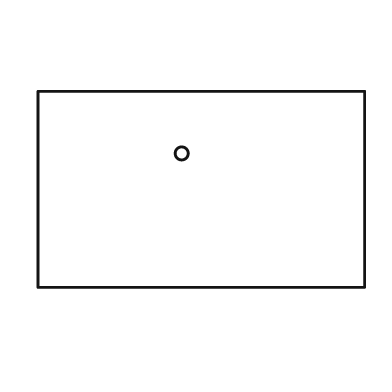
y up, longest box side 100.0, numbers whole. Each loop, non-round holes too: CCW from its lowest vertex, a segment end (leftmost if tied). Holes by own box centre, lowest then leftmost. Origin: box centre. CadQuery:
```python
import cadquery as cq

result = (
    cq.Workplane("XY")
    .moveTo(-50.0, -30.0)
    .lineTo(50.0, -30.0)
    .lineTo(50.0, 30.0)
    .lineTo(-50.0, 30.0)
    .close()
    .moveTo(-6.0, 11.0)
    .circle(2.0)
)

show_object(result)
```